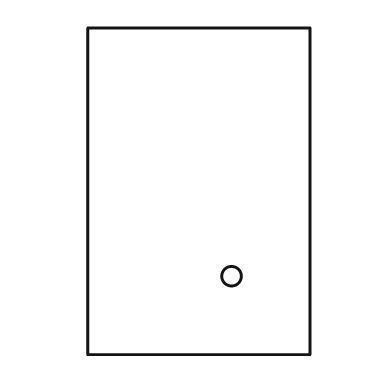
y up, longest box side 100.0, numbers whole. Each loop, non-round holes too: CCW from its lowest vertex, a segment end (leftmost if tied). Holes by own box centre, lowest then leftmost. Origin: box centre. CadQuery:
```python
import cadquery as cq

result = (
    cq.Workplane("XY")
    .moveTo(-34.0, -50.0)
    .lineTo(34.0, -50.0)
    .lineTo(34.0, 50.0)
    .lineTo(-34.0, 50.0)
    .close()
    .moveTo(10.0, -26.0)
    .circle(3.0)
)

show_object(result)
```